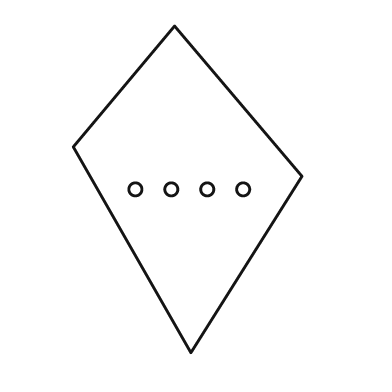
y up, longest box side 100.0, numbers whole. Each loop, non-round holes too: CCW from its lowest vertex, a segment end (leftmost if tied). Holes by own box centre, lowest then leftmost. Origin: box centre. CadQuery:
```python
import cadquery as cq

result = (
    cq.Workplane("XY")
    .moveTo(1.0, -50.0)
    .lineTo(35.0, 4.0)
    .lineTo(-4.0, 50.0)
    .lineTo(-35.0, 13.0)
    .close()
    .moveTo(-16.0, 0.0)
    .circle(2.0)
    .moveTo(-5.0, 0.0)
    .circle(2.0)
    .moveTo(6.0, 0.0)
    .circle(2.0)
    .moveTo(17.0, 0.0)
    .circle(2.0)
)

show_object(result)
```